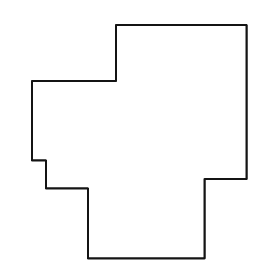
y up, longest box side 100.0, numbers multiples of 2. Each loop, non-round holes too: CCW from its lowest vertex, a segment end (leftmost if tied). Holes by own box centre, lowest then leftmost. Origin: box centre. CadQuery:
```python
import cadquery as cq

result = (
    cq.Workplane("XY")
    .moveTo(-22.0, -50.0)
    .lineTo(28.0, -50.0)
    .lineTo(28.0, -16.0)
    .lineTo(46.0, -16.0)
    .lineTo(46.0, 50.0)
    .lineTo(-10.0, 50.0)
    .lineTo(-10.0, 26.0)
    .lineTo(-46.0, 26.0)
    .lineTo(-46.0, -8.0)
    .lineTo(-40.0, -8.0)
    .lineTo(-40.0, -20.0)
    .lineTo(-22.0, -20.0)
    .close()
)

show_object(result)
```